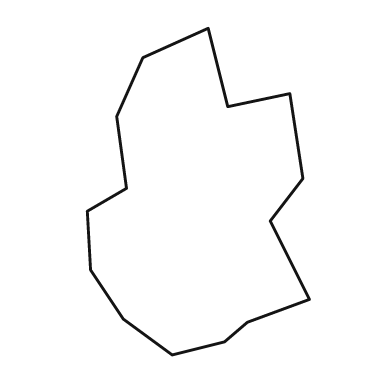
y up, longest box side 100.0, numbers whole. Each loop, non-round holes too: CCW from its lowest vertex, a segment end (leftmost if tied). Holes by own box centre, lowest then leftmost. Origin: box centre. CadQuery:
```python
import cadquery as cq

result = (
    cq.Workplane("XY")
    .moveTo(-8.0, -50.0)
    .lineTo(8.0, -46.0)
    .lineTo(15.0, -40.0)
    .lineTo(34.0, -33.0)
    .lineTo(22.0, -9.0)
    .lineTo(32.0, 4.0)
    .lineTo(28.0, 30.0)
    .lineTo(9.0, 26.0)
    .lineTo(3.0, 50.0)
    .lineTo(-17.0, 41.0)
    .lineTo(-25.0, 23.0)
    .lineTo(-22.0, 1.0)
    .lineTo(-34.0, -6.0)
    .lineTo(-33.0, -24.0)
    .lineTo(-23.0, -39.0)
    .close()
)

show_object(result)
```